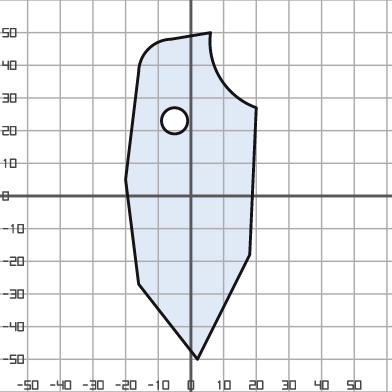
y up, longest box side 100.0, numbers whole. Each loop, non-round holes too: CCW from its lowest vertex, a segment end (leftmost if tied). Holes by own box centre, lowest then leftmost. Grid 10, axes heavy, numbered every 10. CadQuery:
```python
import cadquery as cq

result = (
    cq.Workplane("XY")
    .moveTo(2.0, -50.0)
    .lineTo(18.0, -18.0)
    .lineTo(20.0, 27.0)
    .threePointArc((9.0, 36.0), (6.0, 50.0))
    .lineTo(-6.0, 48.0)
    .threePointArc((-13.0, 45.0), (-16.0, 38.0))
    .lineTo(-20.0, 5.0)
    .lineTo(-16.0, -27.0)
    .close()
    .moveTo(-5.0, 23.0)
    .circle(4.0)
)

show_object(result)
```